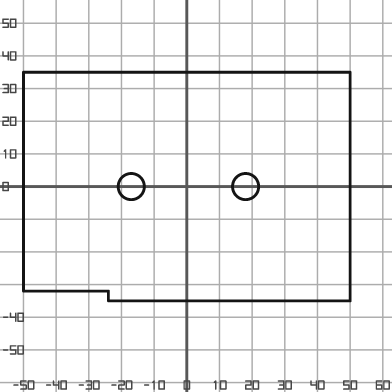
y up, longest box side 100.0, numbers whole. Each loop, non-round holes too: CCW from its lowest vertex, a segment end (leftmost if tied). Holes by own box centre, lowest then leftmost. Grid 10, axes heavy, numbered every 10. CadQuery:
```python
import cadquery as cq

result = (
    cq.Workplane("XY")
    .moveTo(-24.0, -35.0)
    .lineTo(50.0, -35.0)
    .lineTo(50.0, 35.0)
    .lineTo(-50.0, 35.0)
    .lineTo(-50.0, -32.0)
    .lineTo(-24.0, -32.0)
    .close()
    .moveTo(-17.0, 0.0)
    .circle(4.0)
    .moveTo(18.0, 0.0)
    .circle(4.0)
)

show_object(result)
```